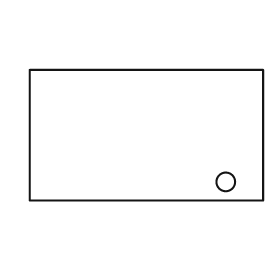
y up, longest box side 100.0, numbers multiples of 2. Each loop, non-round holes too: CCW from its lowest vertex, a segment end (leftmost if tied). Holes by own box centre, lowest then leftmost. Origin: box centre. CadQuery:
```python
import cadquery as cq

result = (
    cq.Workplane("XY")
    .moveTo(-50.0, -28.0)
    .lineTo(50.0, -28.0)
    .lineTo(50.0, 28.0)
    .lineTo(-50.0, 28.0)
    .close()
    .moveTo(34.0, -20.0)
    .circle(4.0)
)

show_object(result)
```